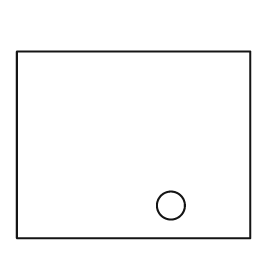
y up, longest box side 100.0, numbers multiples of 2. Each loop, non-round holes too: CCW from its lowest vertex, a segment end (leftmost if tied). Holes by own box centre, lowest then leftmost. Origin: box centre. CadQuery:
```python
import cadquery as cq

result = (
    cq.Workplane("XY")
    .moveTo(-50.0, -40.0)
    .lineTo(50.0, -40.0)
    .lineTo(50.0, 40.0)
    .lineTo(-50.0, 40.0)
    .close()
    .moveTo(16.0, -26.0)
    .circle(6.0)
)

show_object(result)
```